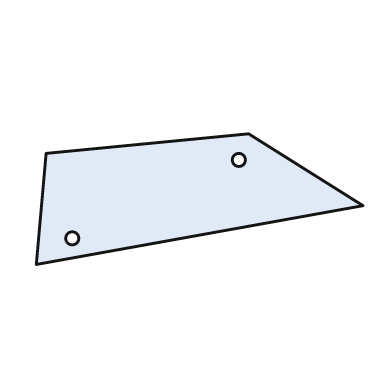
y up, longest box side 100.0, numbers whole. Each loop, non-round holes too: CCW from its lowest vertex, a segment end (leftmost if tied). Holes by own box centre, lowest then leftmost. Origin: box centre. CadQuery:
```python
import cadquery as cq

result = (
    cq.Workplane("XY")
    .moveTo(-50.0, -20.0)
    .lineTo(50.0, -2.0)
    .lineTo(15.0, 20.0)
    .lineTo(-47.0, 14.0)
    .close()
    .moveTo(-39.0, -12.0)
    .circle(2.0)
    .moveTo(12.0, 12.0)
    .circle(2.0)
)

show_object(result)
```